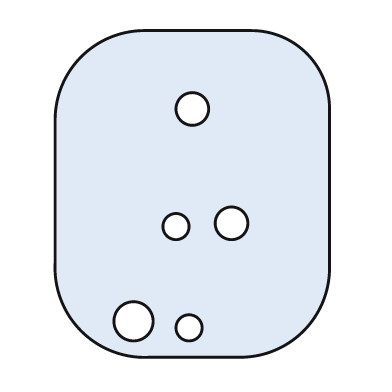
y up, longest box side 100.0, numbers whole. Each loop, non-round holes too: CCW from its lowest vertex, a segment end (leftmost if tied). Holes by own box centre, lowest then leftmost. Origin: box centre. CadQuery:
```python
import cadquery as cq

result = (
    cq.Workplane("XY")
    .moveTo(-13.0, -50.0)
    .lineTo(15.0, -50.0)
    .threePointArc((34.0, -42.0), (42.0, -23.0))
    .lineTo(42.0, 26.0)
    .threePointArc((35.0, 43.0), (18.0, 50.0))
    .lineTo(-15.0, 50.0)
    .threePointArc((-34.0, 42.0), (-42.0, 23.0))
    .lineTo(-42.0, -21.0)
    .threePointArc((-34.0, -42.0), (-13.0, -50.0))
    .close()
    .moveTo(-1.0, -41.0)
    .circle(4.0)
    .moveTo(-18.0, -39.0)
    .circle(6.0)
    .moveTo(-5.0, -10.0)
    .circle(4.0)
    .moveTo(12.0, -9.0)
    .circle(5.0)
    .moveTo(0.0, 26.0)
    .circle(5.0)
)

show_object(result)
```